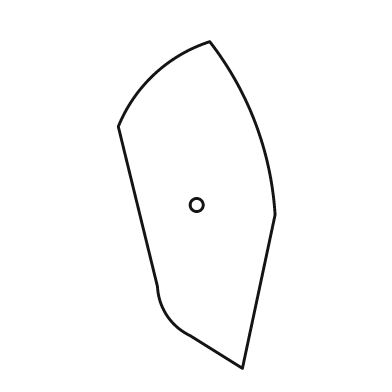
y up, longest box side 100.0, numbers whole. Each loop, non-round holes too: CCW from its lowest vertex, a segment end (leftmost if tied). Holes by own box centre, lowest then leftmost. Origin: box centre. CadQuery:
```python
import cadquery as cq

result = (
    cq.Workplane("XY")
    .moveTo(14.0, -50.0)
    .lineTo(24.0, -3.0)
    .threePointArc((18.0, 25.0), (4.0, 50.0))
    .threePointArc((-13.0, 40.0), (-24.0, 24.0))
    .lineTo(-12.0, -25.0)
    .threePointArc((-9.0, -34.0), (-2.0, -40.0))
    .close()
    .moveTo(0.0, 0.0)
    .circle(2.0)
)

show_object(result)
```